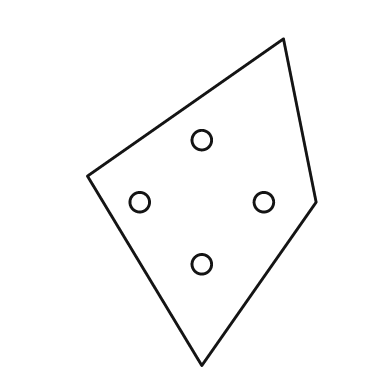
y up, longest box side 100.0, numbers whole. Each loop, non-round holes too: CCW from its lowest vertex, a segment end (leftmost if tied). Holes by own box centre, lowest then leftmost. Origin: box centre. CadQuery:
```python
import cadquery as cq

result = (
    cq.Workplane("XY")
    .moveTo(0.0, -50.0)
    .lineTo(35.0, 0.0)
    .lineTo(25.0, 50.0)
    .lineTo(-35.0, 8.0)
    .close()
    .moveTo(0.0, -19.0)
    .circle(3.0)
    .moveTo(-19.0, 0.0)
    .circle(3.0)
    .moveTo(19.0, 0.0)
    .circle(3.0)
    .moveTo(0.0, 19.0)
    .circle(3.0)
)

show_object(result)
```